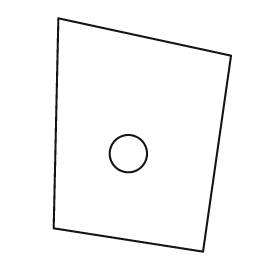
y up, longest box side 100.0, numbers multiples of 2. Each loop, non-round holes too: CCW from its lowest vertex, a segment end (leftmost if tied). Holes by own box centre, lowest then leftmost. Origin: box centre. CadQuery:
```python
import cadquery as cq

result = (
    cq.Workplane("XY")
    .moveTo(26.0, -50.0)
    .lineTo(38.0, 34.0)
    .lineTo(-36.0, 50.0)
    .lineTo(-38.0, -40.0)
    .close()
    .moveTo(-6.0, -8.0)
    .circle(8.0)
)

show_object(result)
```